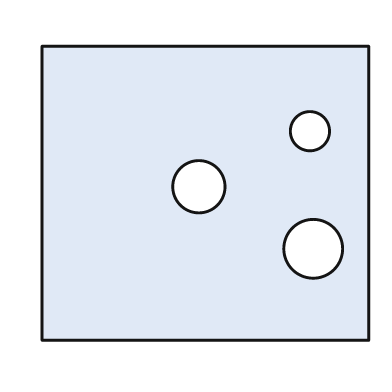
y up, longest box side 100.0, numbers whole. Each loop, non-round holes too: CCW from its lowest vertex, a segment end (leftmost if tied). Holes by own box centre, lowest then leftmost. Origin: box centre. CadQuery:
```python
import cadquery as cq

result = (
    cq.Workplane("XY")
    .moveTo(-50.0, -45.0)
    .lineTo(50.0, -45.0)
    .lineTo(50.0, 45.0)
    .lineTo(-50.0, 45.0)
    .close()
    .moveTo(33.0, -17.0)
    .circle(9.0)
    .moveTo(-2.0, 2.0)
    .circle(8.0)
    .moveTo(32.0, 19.0)
    .circle(6.0)
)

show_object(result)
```